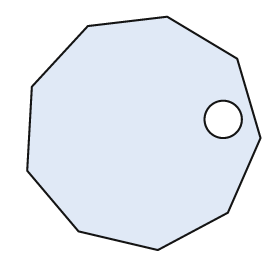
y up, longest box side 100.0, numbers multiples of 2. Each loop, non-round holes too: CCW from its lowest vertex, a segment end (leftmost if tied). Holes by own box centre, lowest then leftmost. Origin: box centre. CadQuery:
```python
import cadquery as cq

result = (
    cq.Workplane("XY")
    .moveTo(6.0, -50.0)
    .lineTo(36.0, -34.0)
    .lineTo(50.0, -2.0)
    .lineTo(40.0, 32.0)
    .lineTo(10.0, 50.0)
    .lineTo(-24.0, 46.0)
    .lineTo(-48.0, 20.0)
    .lineTo(-50.0, -16.0)
    .lineTo(-28.0, -42.0)
    .close()
    .moveTo(34.0, 6.0)
    .circle(8.0)
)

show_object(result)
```